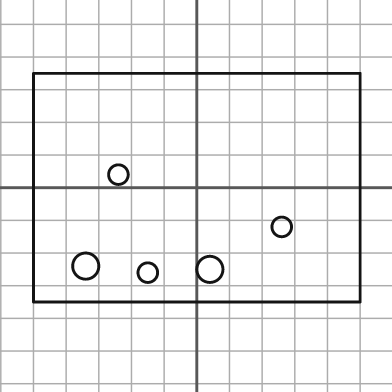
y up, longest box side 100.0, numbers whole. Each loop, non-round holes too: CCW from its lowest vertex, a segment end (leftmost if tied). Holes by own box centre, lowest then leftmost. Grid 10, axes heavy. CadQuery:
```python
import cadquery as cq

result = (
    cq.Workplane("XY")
    .moveTo(-50.0, -35.0)
    .lineTo(50.0, -35.0)
    .lineTo(50.0, 35.0)
    .lineTo(-50.0, 35.0)
    .close()
    .moveTo(-15.0, -26.0)
    .circle(3.0)
    .moveTo(4.0, -25.0)
    .circle(4.0)
    .moveTo(-34.0, -24.0)
    .circle(4.0)
    .moveTo(26.0, -12.0)
    .circle(3.0)
    .moveTo(-24.0, 4.0)
    .circle(3.0)
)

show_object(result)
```